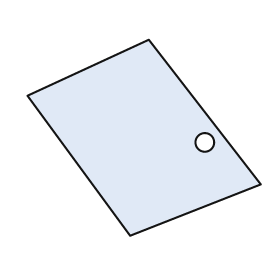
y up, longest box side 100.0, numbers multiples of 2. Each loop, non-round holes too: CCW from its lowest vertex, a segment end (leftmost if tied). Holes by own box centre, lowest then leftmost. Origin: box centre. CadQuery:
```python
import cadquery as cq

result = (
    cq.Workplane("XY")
    .moveTo(-6.0, -42.0)
    .lineTo(50.0, -20.0)
    .lineTo(2.0, 42.0)
    .lineTo(-50.0, 18.0)
    .close()
    .moveTo(26.0, -2.0)
    .circle(4.0)
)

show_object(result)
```